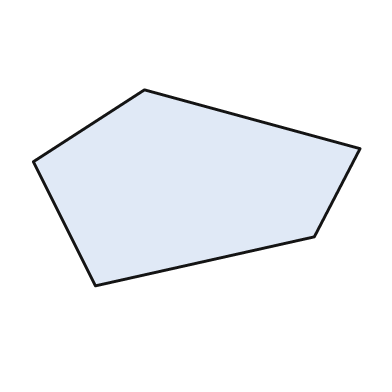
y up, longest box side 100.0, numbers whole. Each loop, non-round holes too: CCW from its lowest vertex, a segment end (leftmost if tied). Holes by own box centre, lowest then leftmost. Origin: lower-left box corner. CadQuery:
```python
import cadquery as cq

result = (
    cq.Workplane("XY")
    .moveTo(19.0, 0.0)
    .lineTo(86.0, 15.0)
    .lineTo(100.0, 42.0)
    .lineTo(34.0, 60.0)
    .lineTo(0.0, 38.0)
    .close()
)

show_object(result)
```